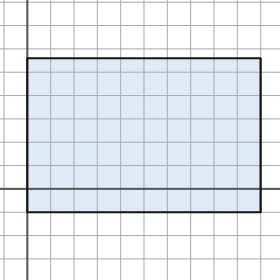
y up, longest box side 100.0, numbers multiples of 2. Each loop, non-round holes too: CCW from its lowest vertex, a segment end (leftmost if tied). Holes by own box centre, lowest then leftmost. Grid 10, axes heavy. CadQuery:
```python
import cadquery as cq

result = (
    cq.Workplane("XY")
    .moveTo(0.0, -10.0)
    .lineTo(100.0, -10.0)
    .lineTo(100.0, 56.0)
    .lineTo(0.0, 56.0)
    .close()
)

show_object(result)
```